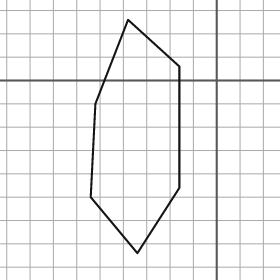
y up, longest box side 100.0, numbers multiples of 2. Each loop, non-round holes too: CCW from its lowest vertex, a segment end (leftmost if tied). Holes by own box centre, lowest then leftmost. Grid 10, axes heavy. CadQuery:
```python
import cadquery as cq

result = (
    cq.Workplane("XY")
    .moveTo(-34.0, -74.0)
    .lineTo(-16.0, -46.0)
    .lineTo(-16.0, 6.0)
    .lineTo(-38.0, 26.0)
    .lineTo(-52.0, -10.0)
    .lineTo(-54.0, -50.0)
    .close()
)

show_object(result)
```